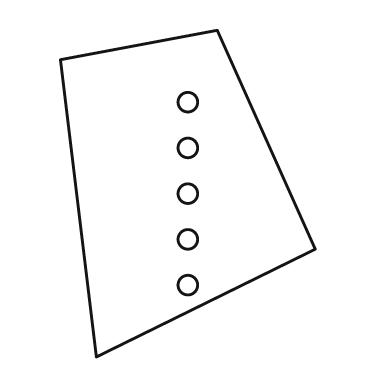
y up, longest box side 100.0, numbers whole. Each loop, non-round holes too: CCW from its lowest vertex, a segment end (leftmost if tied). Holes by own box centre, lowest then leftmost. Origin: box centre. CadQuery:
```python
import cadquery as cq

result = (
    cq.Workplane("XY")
    .moveTo(-28.0, -50.0)
    .lineTo(39.0, -17.0)
    .lineTo(9.0, 50.0)
    .lineTo(-39.0, 41.0)
    .close()
    .moveTo(0.0, -28.0)
    .circle(3.0)
    .moveTo(0.0, -14.0)
    .circle(3.0)
    .moveTo(0.0, 0.0)
    .circle(3.0)
    .moveTo(0.0, 14.0)
    .circle(3.0)
    .moveTo(0.0, 28.0)
    .circle(3.0)
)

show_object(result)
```